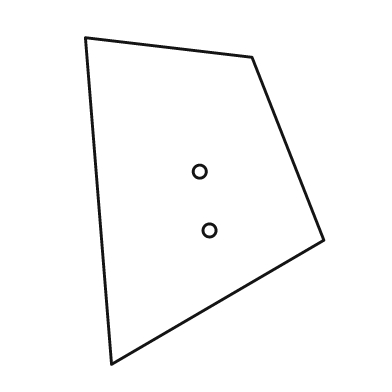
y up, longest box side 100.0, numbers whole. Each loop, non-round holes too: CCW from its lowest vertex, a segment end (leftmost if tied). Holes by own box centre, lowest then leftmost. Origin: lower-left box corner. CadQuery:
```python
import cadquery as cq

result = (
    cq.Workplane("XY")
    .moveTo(8.0, 0.0)
    .lineTo(73.0, 38.0)
    .lineTo(51.0, 94.0)
    .lineTo(0.0, 100.0)
    .close()
    .moveTo(38.0, 41.0)
    .circle(2.0)
    .moveTo(35.0, 59.0)
    .circle(2.0)
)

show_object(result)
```